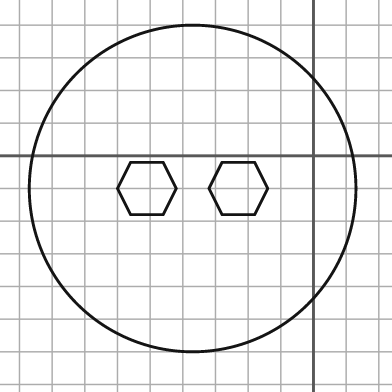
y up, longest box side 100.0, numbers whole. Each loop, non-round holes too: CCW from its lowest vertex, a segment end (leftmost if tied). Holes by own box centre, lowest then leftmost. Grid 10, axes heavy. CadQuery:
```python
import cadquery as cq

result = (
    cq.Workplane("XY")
    .moveTo(-37.0, -10.0)
    .circle(50.0)
    .moveTo(-56.0, -18.0)
    .lineTo(-46.0, -18.0)
    .lineTo(-42.0, -10.0)
    .lineTo(-46.0, -2.0)
    .lineTo(-56.0, -2.0)
    .lineTo(-60.0, -10.0)
    .close()
    .moveTo(-28.0, -18.0)
    .lineTo(-18.0, -18.0)
    .lineTo(-14.0, -10.0)
    .lineTo(-18.0, -2.0)
    .lineTo(-28.0, -2.0)
    .lineTo(-32.0, -10.0)
    .close()
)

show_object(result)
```